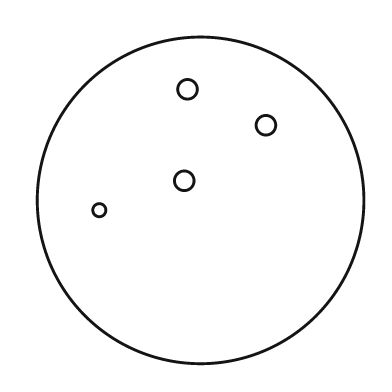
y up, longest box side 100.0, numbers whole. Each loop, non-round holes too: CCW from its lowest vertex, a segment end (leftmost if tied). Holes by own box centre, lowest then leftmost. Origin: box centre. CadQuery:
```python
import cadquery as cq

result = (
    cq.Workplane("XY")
    .moveTo(0.0, 0.0)
    .circle(50.0)
    .moveTo(-31.0, -3.0)
    .circle(2.0)
    .moveTo(-5.0, 6.0)
    .circle(3.0)
    .moveTo(20.0, 23.0)
    .circle(3.0)
    .moveTo(-4.0, 34.0)
    .circle(3.0)
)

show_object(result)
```